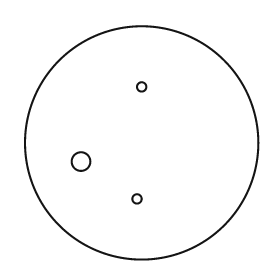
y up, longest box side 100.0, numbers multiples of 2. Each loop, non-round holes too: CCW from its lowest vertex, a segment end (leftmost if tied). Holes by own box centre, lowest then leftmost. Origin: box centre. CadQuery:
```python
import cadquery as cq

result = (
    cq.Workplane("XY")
    .moveTo(0.0, 0.0)
    .circle(50.0)
    .moveTo(-2.0, -24.0)
    .circle(2.0)
    .moveTo(-26.0, -8.0)
    .circle(4.0)
    .moveTo(0.0, 24.0)
    .circle(2.0)
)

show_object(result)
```